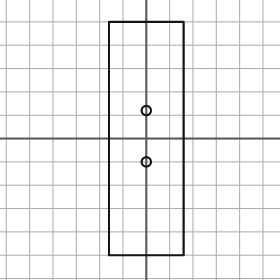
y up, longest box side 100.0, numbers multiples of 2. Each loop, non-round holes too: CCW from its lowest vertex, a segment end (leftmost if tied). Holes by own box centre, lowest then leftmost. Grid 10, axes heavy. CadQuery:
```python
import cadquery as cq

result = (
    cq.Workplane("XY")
    .moveTo(-16.0, -50.0)
    .lineTo(16.0, -50.0)
    .lineTo(16.0, 50.0)
    .lineTo(-16.0, 50.0)
    .close()
    .moveTo(0.0, -10.0)
    .circle(2.0)
    .moveTo(0.0, 12.0)
    .circle(2.0)
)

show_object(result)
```